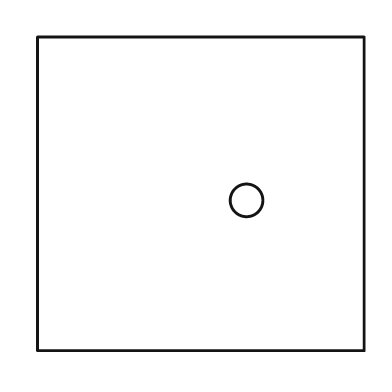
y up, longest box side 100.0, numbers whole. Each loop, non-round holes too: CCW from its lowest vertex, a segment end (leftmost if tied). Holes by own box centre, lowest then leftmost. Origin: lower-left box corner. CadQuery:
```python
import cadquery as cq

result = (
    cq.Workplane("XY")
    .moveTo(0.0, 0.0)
    .lineTo(100.0, 0.0)
    .lineTo(100.0, 96.0)
    .lineTo(0.0, 96.0)
    .close()
    .moveTo(64.0, 46.0)
    .circle(5.0)
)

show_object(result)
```